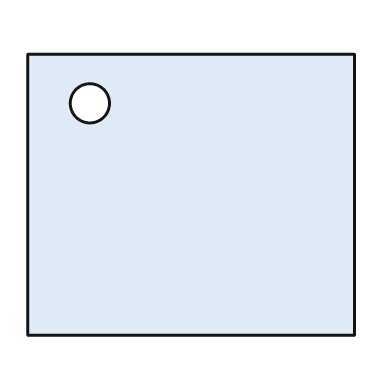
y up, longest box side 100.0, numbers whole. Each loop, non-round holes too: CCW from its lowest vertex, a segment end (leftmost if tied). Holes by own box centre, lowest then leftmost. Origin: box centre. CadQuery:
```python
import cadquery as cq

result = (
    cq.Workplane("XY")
    .moveTo(-50.0, -43.0)
    .lineTo(50.0, -43.0)
    .lineTo(50.0, 43.0)
    .lineTo(-50.0, 43.0)
    .close()
    .moveTo(-31.0, 28.0)
    .circle(6.0)
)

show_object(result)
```